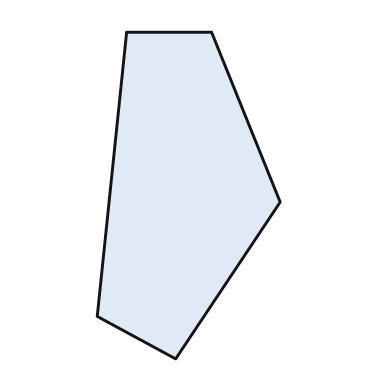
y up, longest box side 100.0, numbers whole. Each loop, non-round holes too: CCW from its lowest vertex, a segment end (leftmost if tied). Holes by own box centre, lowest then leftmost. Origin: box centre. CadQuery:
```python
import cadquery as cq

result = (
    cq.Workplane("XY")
    .moveTo(-4.0, -50.0)
    .lineTo(28.0, -2.0)
    .lineTo(7.0, 50.0)
    .lineTo(-19.0, 50.0)
    .lineTo(-28.0, -37.0)
    .close()
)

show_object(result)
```